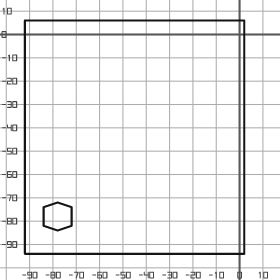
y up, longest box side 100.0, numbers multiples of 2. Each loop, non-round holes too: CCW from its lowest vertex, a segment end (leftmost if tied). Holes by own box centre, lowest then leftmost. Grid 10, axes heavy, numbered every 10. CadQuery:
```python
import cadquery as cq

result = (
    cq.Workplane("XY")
    .moveTo(-92.0, -94.0)
    .lineTo(2.0, -94.0)
    .lineTo(2.0, 6.0)
    .lineTo(-92.0, 6.0)
    .close()
    .moveTo(-78.0, -84.0)
    .lineTo(-72.0, -82.0)
    .lineTo(-72.0, -74.0)
    .lineTo(-78.0, -72.0)
    .lineTo(-84.0, -74.0)
    .lineTo(-84.0, -82.0)
    .close()
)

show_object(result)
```